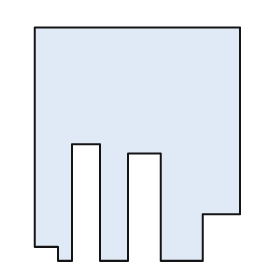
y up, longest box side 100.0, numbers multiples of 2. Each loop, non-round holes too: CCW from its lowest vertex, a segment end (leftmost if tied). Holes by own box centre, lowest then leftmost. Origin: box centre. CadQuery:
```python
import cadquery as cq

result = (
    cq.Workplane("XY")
    .moveTo(-34.0, -50.0)
    .lineTo(-28.0, -50.0)
    .lineTo(-28.0, 0.0)
    .lineTo(-16.0, 0.0)
    .lineTo(-16.0, -50.0)
    .lineTo(-4.0, -50.0)
    .lineTo(-4.0, -4.0)
    .lineTo(10.0, -4.0)
    .lineTo(10.0, -50.0)
    .lineTo(28.0, -50.0)
    .lineTo(28.0, -30.0)
    .lineTo(44.0, -30.0)
    .lineTo(44.0, 50.0)
    .lineTo(-44.0, 50.0)
    .lineTo(-44.0, -44.0)
    .lineTo(-34.0, -44.0)
    .close()
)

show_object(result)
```